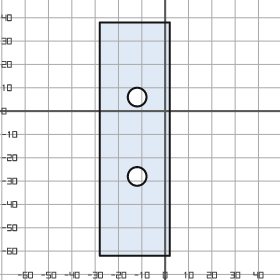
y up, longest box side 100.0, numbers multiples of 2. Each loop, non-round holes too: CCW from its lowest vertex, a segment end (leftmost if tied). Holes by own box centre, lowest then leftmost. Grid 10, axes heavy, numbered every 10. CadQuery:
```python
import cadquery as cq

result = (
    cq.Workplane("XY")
    .moveTo(-28.0, -62.0)
    .lineTo(2.0, -62.0)
    .lineTo(2.0, 38.0)
    .lineTo(-28.0, 38.0)
    .close()
    .moveTo(-12.0, -28.0)
    .circle(4.0)
    .moveTo(-12.0, 6.0)
    .circle(4.0)
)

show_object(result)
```